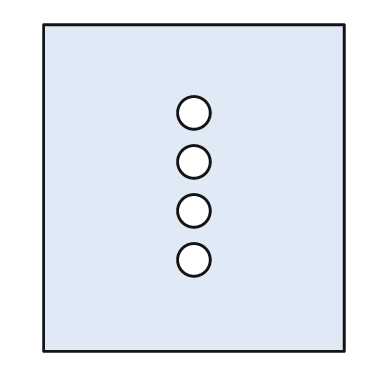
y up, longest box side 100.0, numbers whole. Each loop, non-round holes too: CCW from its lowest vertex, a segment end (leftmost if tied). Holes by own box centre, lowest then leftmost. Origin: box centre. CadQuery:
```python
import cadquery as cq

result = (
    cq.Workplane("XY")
    .moveTo(-46.0, -50.0)
    .lineTo(46.0, -50.0)
    .lineTo(46.0, 50.0)
    .lineTo(-46.0, 50.0)
    .close()
    .moveTo(0.0, -22.0)
    .circle(5.0)
    .moveTo(0.0, -7.0)
    .circle(5.0)
    .moveTo(0.0, 8.0)
    .circle(5.0)
    .moveTo(0.0, 23.0)
    .circle(5.0)
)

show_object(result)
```